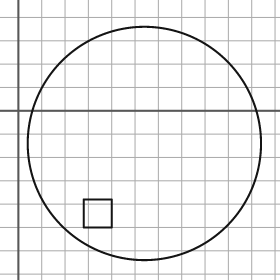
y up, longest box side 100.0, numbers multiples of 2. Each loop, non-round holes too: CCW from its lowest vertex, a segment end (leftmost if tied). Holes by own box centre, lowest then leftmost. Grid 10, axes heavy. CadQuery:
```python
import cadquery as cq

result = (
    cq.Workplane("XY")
    .moveTo(54.0, -14.0)
    .circle(50.0)
    .moveTo(28.0, -50.0)
    .lineTo(40.0, -50.0)
    .lineTo(40.0, -38.0)
    .lineTo(28.0, -38.0)
    .close()
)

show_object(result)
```